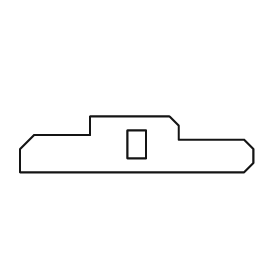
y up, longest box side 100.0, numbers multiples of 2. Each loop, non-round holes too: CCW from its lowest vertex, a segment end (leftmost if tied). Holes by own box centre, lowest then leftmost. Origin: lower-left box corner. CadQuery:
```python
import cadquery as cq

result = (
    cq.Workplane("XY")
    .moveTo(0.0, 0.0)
    .lineTo(96.0, 0.0)
    .lineTo(100.0, 4.0)
    .lineTo(100.0, 10.0)
    .lineTo(96.0, 14.0)
    .lineTo(68.0, 14.0)
    .lineTo(68.0, 20.0)
    .lineTo(64.0, 24.0)
    .lineTo(30.0, 24.0)
    .lineTo(30.0, 16.0)
    .lineTo(6.0, 16.0)
    .lineTo(0.0, 10.0)
    .close()
    .moveTo(46.0, 6.0)
    .lineTo(54.0, 6.0)
    .lineTo(54.0, 18.0)
    .lineTo(46.0, 18.0)
    .close()
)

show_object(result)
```